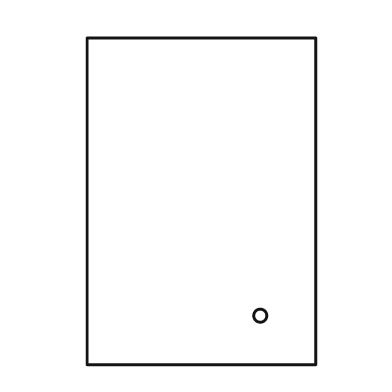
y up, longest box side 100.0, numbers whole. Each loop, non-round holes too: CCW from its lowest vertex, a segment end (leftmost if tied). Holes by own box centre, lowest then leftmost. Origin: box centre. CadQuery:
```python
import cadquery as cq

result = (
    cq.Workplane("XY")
    .moveTo(-35.0, -50.0)
    .lineTo(35.0, -50.0)
    .lineTo(35.0, 50.0)
    .lineTo(-35.0, 50.0)
    .close()
    .moveTo(18.0, -35.0)
    .circle(2.0)
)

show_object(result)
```